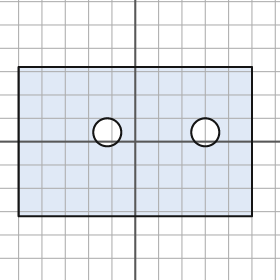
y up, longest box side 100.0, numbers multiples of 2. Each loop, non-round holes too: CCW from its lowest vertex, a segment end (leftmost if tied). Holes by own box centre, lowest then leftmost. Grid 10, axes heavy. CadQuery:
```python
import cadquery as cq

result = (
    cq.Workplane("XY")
    .moveTo(-50.0, -32.0)
    .lineTo(50.0, -32.0)
    .lineTo(50.0, 32.0)
    .lineTo(-50.0, 32.0)
    .close()
    .moveTo(-12.0, 4.0)
    .circle(6.0)
    .moveTo(30.0, 4.0)
    .circle(6.0)
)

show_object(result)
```